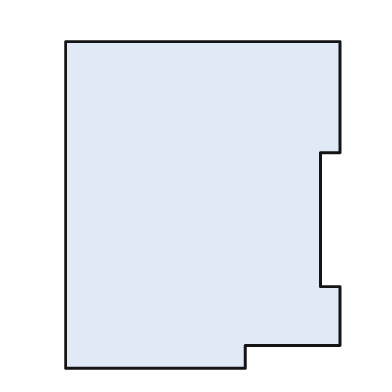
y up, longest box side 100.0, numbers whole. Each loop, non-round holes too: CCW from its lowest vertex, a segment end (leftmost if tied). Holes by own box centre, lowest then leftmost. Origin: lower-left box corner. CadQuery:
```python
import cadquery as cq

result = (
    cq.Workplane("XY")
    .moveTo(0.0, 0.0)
    .lineTo(55.0, 0.0)
    .lineTo(55.0, 7.0)
    .lineTo(84.0, 7.0)
    .lineTo(84.0, 25.0)
    .lineTo(78.0, 25.0)
    .lineTo(78.0, 66.0)
    .lineTo(84.0, 66.0)
    .lineTo(84.0, 100.0)
    .lineTo(0.0, 100.0)
    .close()
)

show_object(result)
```